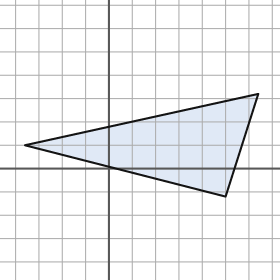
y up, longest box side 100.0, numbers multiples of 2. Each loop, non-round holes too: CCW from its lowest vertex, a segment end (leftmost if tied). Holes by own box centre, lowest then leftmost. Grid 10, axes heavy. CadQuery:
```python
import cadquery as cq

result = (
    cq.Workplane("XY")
    .moveTo(50.0, -12.0)
    .lineTo(64.0, 32.0)
    .lineTo(-36.0, 10.0)
    .close()
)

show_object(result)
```